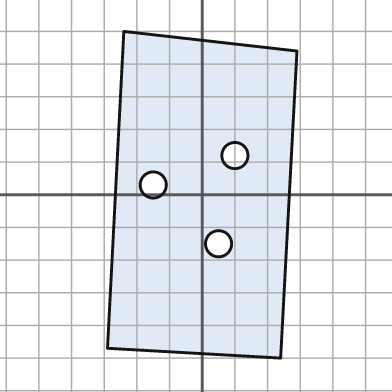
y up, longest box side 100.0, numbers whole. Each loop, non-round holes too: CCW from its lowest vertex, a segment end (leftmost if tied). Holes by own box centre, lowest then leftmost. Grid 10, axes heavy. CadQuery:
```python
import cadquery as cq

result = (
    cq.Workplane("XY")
    .moveTo(24.0, -50.0)
    .lineTo(29.0, 44.0)
    .lineTo(-24.0, 50.0)
    .lineTo(-29.0, -47.0)
    .close()
    .moveTo(5.0, -15.0)
    .circle(4.0)
    .moveTo(-15.0, 3.0)
    .circle(4.0)
    .moveTo(10.0, 12.0)
    .circle(4.0)
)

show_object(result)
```